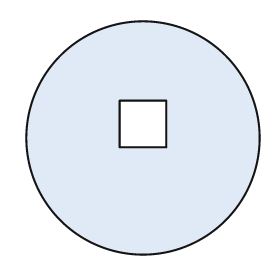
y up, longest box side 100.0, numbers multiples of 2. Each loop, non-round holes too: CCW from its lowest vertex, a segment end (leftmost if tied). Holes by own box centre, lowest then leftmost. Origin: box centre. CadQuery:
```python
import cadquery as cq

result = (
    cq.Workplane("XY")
    .moveTo(0.0, 0.0)
    .circle(50.0)
    .moveTo(-10.0, -4.0)
    .lineTo(10.0, -4.0)
    .lineTo(10.0, 16.0)
    .lineTo(-10.0, 16.0)
    .close()
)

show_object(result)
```